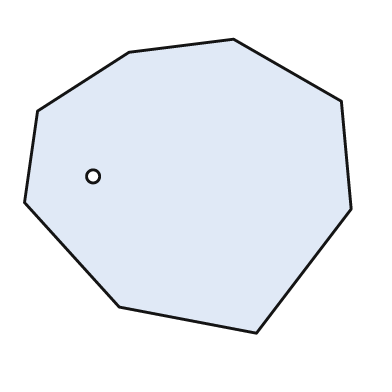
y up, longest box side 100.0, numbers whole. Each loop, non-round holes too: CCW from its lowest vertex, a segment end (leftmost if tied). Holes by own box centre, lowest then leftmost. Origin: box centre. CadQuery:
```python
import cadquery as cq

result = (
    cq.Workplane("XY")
    .moveTo(21.0, -45.0)
    .lineTo(50.0, -7.0)
    .lineTo(47.0, 26.0)
    .lineTo(14.0, 45.0)
    .lineTo(-18.0, 41.0)
    .lineTo(-46.0, 23.0)
    .lineTo(-50.0, -5.0)
    .lineTo(-21.0, -37.0)
    .close()
    .moveTo(-29.0, 3.0)
    .circle(2.0)
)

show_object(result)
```